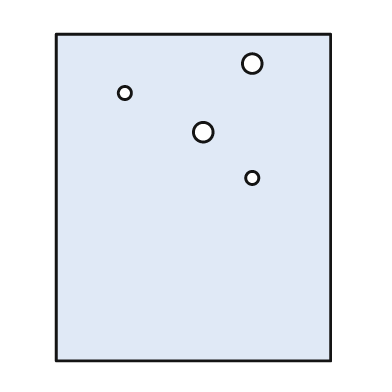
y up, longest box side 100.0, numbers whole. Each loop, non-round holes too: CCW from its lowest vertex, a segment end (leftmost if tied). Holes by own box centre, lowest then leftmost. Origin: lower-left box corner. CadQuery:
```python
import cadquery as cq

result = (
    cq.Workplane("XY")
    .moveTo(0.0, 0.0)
    .lineTo(84.0, 0.0)
    .lineTo(84.0, 100.0)
    .lineTo(0.0, 100.0)
    .close()
    .moveTo(60.0, 56.0)
    .circle(2.0)
    .moveTo(45.0, 70.0)
    .circle(3.0)
    .moveTo(21.0, 82.0)
    .circle(2.0)
    .moveTo(60.0, 91.0)
    .circle(3.0)
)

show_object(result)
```